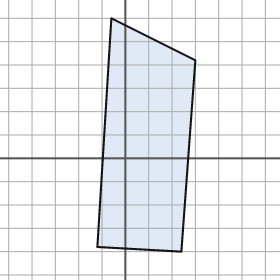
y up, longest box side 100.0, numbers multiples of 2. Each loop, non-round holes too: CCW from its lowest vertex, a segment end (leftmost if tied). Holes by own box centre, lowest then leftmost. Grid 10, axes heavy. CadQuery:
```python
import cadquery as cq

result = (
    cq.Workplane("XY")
    .moveTo(24.0, -40.0)
    .lineTo(30.0, 42.0)
    .lineTo(-6.0, 60.0)
    .lineTo(-12.0, -38.0)
    .close()
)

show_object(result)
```